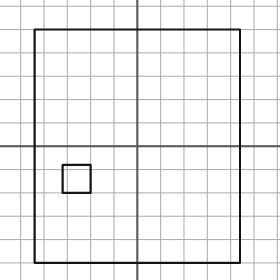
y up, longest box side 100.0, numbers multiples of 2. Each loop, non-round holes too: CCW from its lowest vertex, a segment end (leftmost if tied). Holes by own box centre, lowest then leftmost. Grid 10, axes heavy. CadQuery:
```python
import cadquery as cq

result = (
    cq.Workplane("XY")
    .moveTo(-44.0, -50.0)
    .lineTo(44.0, -50.0)
    .lineTo(44.0, 50.0)
    .lineTo(-44.0, 50.0)
    .close()
    .moveTo(-32.0, -20.0)
    .lineTo(-20.0, -20.0)
    .lineTo(-20.0, -8.0)
    .lineTo(-32.0, -8.0)
    .close()
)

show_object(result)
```